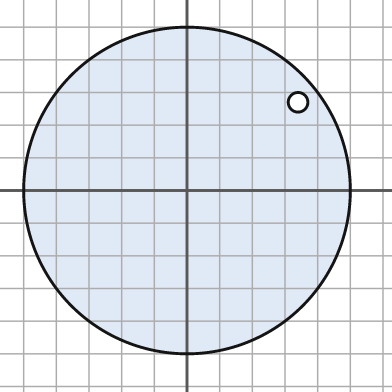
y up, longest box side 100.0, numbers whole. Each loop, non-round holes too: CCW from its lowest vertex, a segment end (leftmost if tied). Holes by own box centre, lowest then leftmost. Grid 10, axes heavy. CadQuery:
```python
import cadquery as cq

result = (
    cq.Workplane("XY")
    .moveTo(0.0, 0.0)
    .circle(50.0)
    .moveTo(34.0, 27.0)
    .circle(3.0)
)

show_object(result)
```